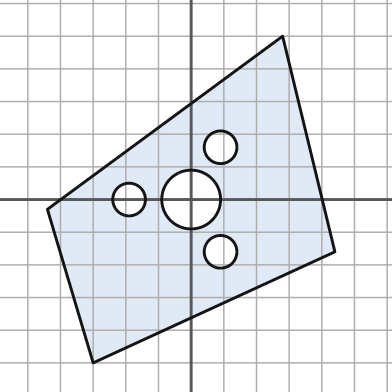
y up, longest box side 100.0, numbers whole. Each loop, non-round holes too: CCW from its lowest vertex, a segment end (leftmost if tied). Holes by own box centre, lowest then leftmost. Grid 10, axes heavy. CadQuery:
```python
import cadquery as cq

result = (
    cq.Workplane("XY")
    .moveTo(-30.0, -50.0)
    .lineTo(44.0, -16.0)
    .lineTo(28.0, 50.0)
    .lineTo(-44.0, -3.0)
    .close()
    .moveTo(9.0, -16.0)
    .circle(5.0)
    .moveTo(-19.0, 0.0)
    .circle(5.0)
    .moveTo(0.0, 0.0)
    .circle(9.0)
    .moveTo(9.0, 16.0)
    .circle(5.0)
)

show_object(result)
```